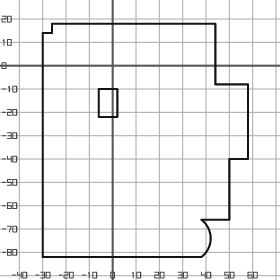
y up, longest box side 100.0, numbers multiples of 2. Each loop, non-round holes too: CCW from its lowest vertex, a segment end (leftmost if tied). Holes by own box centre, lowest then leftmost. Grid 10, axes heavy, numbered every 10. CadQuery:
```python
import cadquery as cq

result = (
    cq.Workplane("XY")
    .moveTo(-30.0, -82.0)
    .lineTo(38.0, -82.0)
    .threePointArc((42.0, -74.0), (38.0, -66.0))
    .lineTo(50.0, -66.0)
    .lineTo(50.0, -40.0)
    .lineTo(58.0, -40.0)
    .lineTo(58.0, -8.0)
    .lineTo(44.0, -8.0)
    .lineTo(44.0, 18.0)
    .lineTo(-26.0, 18.0)
    .lineTo(-26.0, 14.0)
    .lineTo(-30.0, 14.0)
    .close()
    .moveTo(-6.0, -22.0)
    .lineTo(2.0, -22.0)
    .lineTo(2.0, -10.0)
    .lineTo(-6.0, -10.0)
    .close()
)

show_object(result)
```